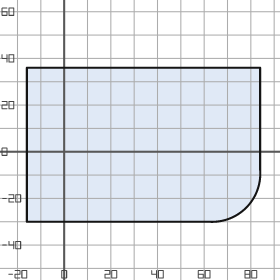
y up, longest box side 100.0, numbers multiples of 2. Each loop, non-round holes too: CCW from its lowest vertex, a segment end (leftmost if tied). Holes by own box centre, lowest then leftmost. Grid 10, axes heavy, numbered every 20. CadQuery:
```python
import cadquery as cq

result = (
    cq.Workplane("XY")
    .moveTo(-16.0, -30.0)
    .lineTo(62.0, -30.0)
    .threePointArc((78.0, -24.0), (84.0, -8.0))
    .lineTo(84.0, 36.0)
    .lineTo(-16.0, 36.0)
    .close()
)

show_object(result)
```